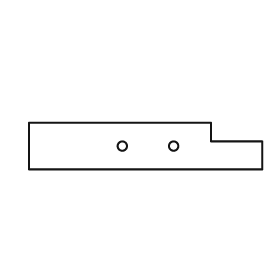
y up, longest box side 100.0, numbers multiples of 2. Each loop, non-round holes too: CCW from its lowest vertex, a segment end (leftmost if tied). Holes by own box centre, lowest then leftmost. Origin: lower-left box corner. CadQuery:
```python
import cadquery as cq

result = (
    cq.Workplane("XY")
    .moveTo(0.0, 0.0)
    .lineTo(100.0, 0.0)
    .lineTo(100.0, 12.0)
    .lineTo(78.0, 12.0)
    .lineTo(78.0, 20.0)
    .lineTo(0.0, 20.0)
    .close()
    .moveTo(40.0, 10.0)
    .circle(2.0)
    .moveTo(62.0, 10.0)
    .circle(2.0)
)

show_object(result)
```